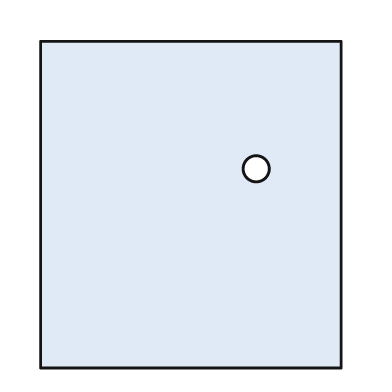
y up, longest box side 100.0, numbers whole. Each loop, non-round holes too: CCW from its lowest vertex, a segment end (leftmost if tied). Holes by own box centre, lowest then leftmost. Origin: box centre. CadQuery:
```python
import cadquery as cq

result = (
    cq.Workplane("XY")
    .moveTo(-46.0, -50.0)
    .lineTo(46.0, -50.0)
    .lineTo(46.0, 50.0)
    .lineTo(-46.0, 50.0)
    .close()
    .moveTo(20.0, 11.0)
    .circle(4.0)
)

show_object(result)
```